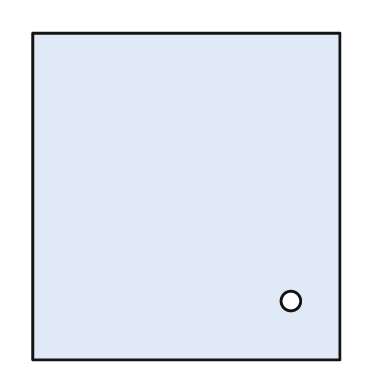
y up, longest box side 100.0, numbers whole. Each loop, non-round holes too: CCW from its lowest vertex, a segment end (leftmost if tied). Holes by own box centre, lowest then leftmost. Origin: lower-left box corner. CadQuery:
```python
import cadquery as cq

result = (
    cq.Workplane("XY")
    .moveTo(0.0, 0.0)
    .lineTo(94.0, 0.0)
    .lineTo(94.0, 100.0)
    .lineTo(0.0, 100.0)
    .close()
    .moveTo(79.0, 18.0)
    .circle(3.0)
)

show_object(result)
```